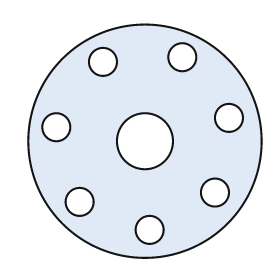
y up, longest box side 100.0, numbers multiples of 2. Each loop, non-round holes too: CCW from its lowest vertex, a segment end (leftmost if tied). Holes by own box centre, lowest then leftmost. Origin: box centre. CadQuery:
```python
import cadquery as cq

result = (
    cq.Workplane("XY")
    .moveTo(0.0, 0.0)
    .circle(50.0)
    .moveTo(2.0, -38.0)
    .circle(6.0)
    .moveTo(-28.0, -26.0)
    .circle(6.0)
    .moveTo(30.0, -22.0)
    .circle(6.0)
    .moveTo(0.0, 0.0)
    .circle(12.0)
    .moveTo(-38.0, 6.0)
    .circle(6.0)
    .moveTo(36.0, 10.0)
    .circle(6.0)
    .moveTo(-18.0, 34.0)
    .circle(6.0)
    .moveTo(16.0, 36.0)
    .circle(6.0)
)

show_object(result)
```